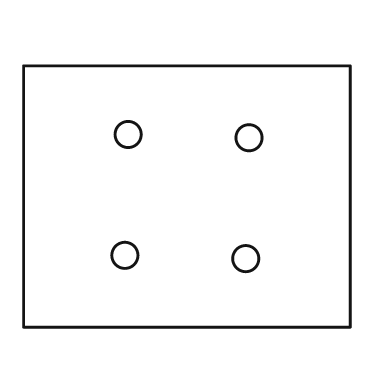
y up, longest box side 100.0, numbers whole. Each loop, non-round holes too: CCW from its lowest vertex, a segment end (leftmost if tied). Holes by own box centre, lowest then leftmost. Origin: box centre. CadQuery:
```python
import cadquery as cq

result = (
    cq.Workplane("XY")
    .moveTo(-50.0, -40.0)
    .lineTo(50.0, -40.0)
    .lineTo(50.0, 40.0)
    .lineTo(-50.0, 40.0)
    .close()
    .moveTo(18.0, -19.0)
    .circle(4.0)
    .moveTo(-19.0, -18.0)
    .circle(4.0)
    .moveTo(19.0, 18.0)
    .circle(4.0)
    .moveTo(-18.0, 19.0)
    .circle(4.0)
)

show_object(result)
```